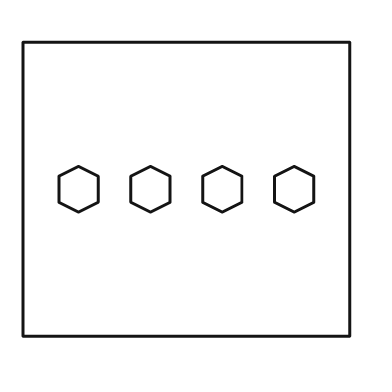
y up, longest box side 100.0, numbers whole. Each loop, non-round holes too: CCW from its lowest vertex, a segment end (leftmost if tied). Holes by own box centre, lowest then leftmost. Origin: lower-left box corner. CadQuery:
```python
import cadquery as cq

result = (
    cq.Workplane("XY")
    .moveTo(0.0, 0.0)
    .lineTo(100.0, 0.0)
    .lineTo(100.0, 90.0)
    .lineTo(0.0, 90.0)
    .close()
    .moveTo(17.0, 38.0)
    .lineTo(23.0, 41.0)
    .lineTo(23.0, 49.0)
    .lineTo(17.0, 52.0)
    .lineTo(11.0, 49.0)
    .lineTo(11.0, 41.0)
    .close()
    .moveTo(39.0, 38.0)
    .lineTo(45.0, 41.0)
    .lineTo(45.0, 49.0)
    .lineTo(39.0, 52.0)
    .lineTo(33.0, 49.0)
    .lineTo(33.0, 41.0)
    .close()
    .moveTo(61.0, 38.0)
    .lineTo(67.0, 41.0)
    .lineTo(67.0, 49.0)
    .lineTo(61.0, 52.0)
    .lineTo(55.0, 49.0)
    .lineTo(55.0, 41.0)
    .close()
    .moveTo(83.0, 38.0)
    .lineTo(89.0, 41.0)
    .lineTo(89.0, 49.0)
    .lineTo(83.0, 52.0)
    .lineTo(77.0, 49.0)
    .lineTo(77.0, 41.0)
    .close()
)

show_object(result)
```